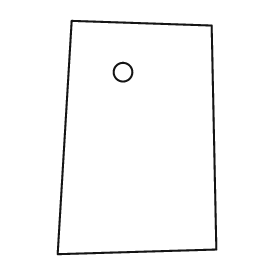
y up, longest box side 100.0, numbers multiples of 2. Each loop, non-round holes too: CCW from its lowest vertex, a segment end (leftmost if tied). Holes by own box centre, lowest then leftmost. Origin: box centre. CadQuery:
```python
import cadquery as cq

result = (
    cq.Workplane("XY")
    .moveTo(-34.0, -50.0)
    .lineTo(34.0, -48.0)
    .lineTo(32.0, 48.0)
    .lineTo(-28.0, 50.0)
    .close()
    .moveTo(-6.0, 28.0)
    .circle(4.0)
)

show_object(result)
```